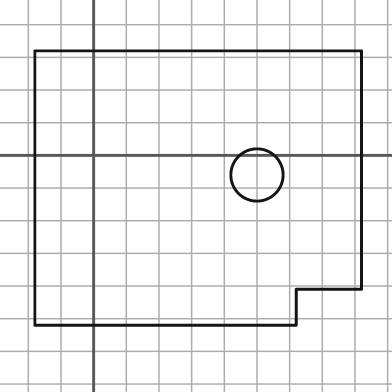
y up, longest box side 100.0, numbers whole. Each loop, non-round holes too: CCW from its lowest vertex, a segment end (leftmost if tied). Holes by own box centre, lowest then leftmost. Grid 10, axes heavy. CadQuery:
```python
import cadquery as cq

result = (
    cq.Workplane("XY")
    .moveTo(-18.0, -52.0)
    .lineTo(62.0, -52.0)
    .lineTo(62.0, -41.0)
    .lineTo(82.0, -41.0)
    .lineTo(82.0, 32.0)
    .lineTo(-18.0, 32.0)
    .close()
    .moveTo(50.0, -6.0)
    .circle(8.0)
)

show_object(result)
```